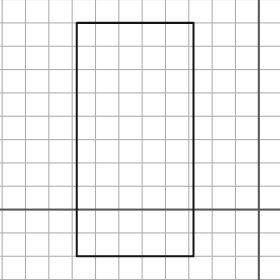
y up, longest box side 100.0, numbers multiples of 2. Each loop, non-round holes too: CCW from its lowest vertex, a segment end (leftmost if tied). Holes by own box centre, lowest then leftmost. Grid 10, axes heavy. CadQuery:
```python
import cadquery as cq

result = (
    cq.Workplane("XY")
    .moveTo(-78.0, -20.0)
    .lineTo(-28.0, -20.0)
    .lineTo(-28.0, 80.0)
    .lineTo(-78.0, 80.0)
    .close()
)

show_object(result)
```